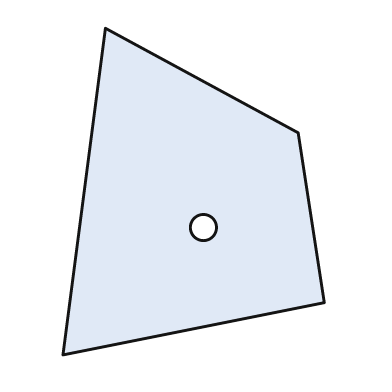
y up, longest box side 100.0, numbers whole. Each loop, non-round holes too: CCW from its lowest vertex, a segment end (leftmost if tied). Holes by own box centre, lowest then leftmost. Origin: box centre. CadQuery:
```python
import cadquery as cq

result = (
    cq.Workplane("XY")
    .moveTo(-40.0, -50.0)
    .lineTo(40.0, -34.0)
    .lineTo(32.0, 18.0)
    .lineTo(-27.0, 50.0)
    .close()
    .moveTo(3.0, -11.0)
    .circle(4.0)
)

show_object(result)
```